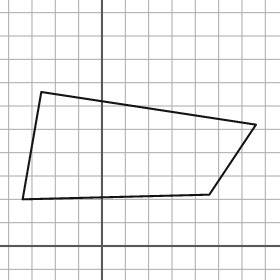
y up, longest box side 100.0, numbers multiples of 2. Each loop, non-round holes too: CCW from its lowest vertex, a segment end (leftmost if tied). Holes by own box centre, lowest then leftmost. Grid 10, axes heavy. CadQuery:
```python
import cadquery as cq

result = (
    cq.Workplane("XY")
    .moveTo(-34.0, 20.0)
    .lineTo(46.0, 22.0)
    .lineTo(66.0, 52.0)
    .lineTo(-26.0, 66.0)
    .close()
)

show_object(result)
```